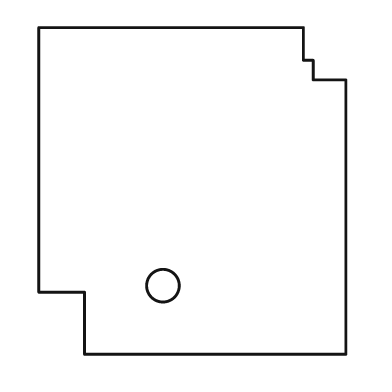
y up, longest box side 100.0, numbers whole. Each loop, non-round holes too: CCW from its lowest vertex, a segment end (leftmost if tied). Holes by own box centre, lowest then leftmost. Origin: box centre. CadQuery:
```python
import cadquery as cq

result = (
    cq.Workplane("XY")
    .moveTo(-33.0, -50.0)
    .lineTo(47.0, -50.0)
    .lineTo(47.0, 34.0)
    .lineTo(37.0, 34.0)
    .lineTo(37.0, 40.0)
    .lineTo(34.0, 40.0)
    .lineTo(34.0, 50.0)
    .lineTo(-47.0, 50.0)
    .lineTo(-47.0, -31.0)
    .lineTo(-33.0, -31.0)
    .close()
    .moveTo(-9.0, -29.0)
    .circle(5.0)
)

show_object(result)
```